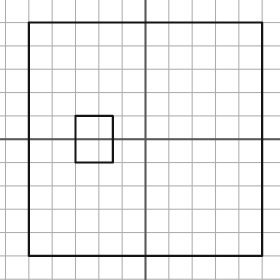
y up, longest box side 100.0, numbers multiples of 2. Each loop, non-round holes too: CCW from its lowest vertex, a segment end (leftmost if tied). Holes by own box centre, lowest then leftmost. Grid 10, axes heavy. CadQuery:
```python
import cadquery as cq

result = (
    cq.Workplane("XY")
    .moveTo(-50.0, -50.0)
    .lineTo(50.0, -50.0)
    .lineTo(50.0, 50.0)
    .lineTo(-50.0, 50.0)
    .close()
    .moveTo(-30.0, -10.0)
    .lineTo(-14.0, -10.0)
    .lineTo(-14.0, 10.0)
    .lineTo(-30.0, 10.0)
    .close()
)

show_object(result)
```